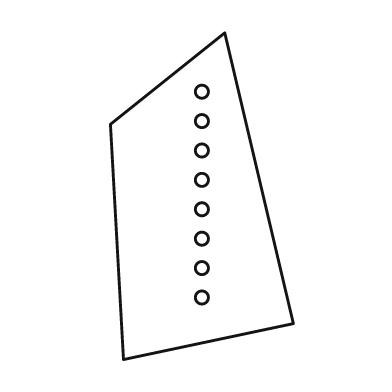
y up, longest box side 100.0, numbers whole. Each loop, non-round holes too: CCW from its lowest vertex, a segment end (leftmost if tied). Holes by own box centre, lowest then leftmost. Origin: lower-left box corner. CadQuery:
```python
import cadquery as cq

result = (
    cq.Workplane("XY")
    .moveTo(4.0, 0.0)
    .lineTo(56.0, 11.0)
    .lineTo(35.0, 100.0)
    .lineTo(0.0, 72.0)
    .close()
    .moveTo(28.0, 19.0)
    .circle(2.0)
    .moveTo(28.0, 28.0)
    .circle(2.0)
    .moveTo(28.0, 37.0)
    .circle(2.0)
    .moveTo(28.0, 46.0)
    .circle(2.0)
    .moveTo(28.0, 55.0)
    .circle(2.0)
    .moveTo(28.0, 64.0)
    .circle(2.0)
    .moveTo(28.0, 73.0)
    .circle(2.0)
    .moveTo(28.0, 82.0)
    .circle(2.0)
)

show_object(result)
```